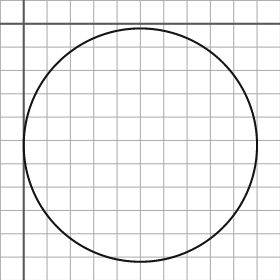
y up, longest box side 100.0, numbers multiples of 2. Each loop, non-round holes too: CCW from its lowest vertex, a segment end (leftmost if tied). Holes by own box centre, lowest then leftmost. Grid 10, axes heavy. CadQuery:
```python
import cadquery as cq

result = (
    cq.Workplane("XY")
    .moveTo(50.0, -52.0)
    .circle(50.0)
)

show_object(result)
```